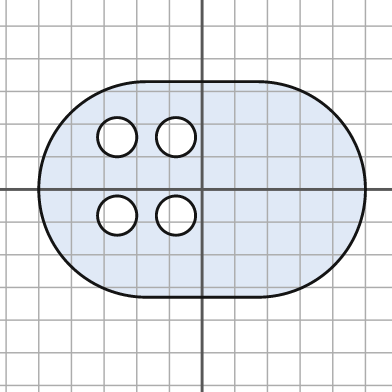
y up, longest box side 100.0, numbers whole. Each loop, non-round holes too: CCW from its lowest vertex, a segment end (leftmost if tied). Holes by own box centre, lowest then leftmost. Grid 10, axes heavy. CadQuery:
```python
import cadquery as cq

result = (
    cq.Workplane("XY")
    .moveTo(-17.0, -33.0)
    .lineTo(17.0, -33.0)
    .threePointArc((50.0, 0.0), (17.0, 33.0))
    .lineTo(-17.0, 33.0)
    .threePointArc((-50.0, 0.0), (-17.0, -33.0))
    .close()
    .moveTo(-26.0, -8.0)
    .circle(6.0)
    .moveTo(-8.0, -8.0)
    .circle(6.0)
    .moveTo(-26.0, 16.0)
    .circle(6.0)
    .moveTo(-8.0, 16.0)
    .circle(6.0)
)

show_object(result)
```